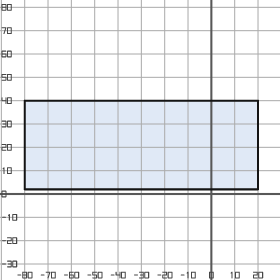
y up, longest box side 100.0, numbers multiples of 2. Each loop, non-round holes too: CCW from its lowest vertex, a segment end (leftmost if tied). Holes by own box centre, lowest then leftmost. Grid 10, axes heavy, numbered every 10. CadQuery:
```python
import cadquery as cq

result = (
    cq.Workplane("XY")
    .moveTo(-80.0, 2.0)
    .lineTo(20.0, 2.0)
    .lineTo(20.0, 40.0)
    .lineTo(-80.0, 40.0)
    .close()
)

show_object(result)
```